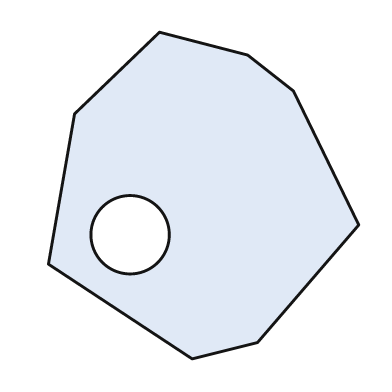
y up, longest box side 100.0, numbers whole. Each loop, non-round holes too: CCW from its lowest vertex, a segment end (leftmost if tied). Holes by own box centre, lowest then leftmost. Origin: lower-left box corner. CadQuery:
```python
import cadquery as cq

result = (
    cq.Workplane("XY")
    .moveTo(44.0, 0.0)
    .lineTo(64.0, 5.0)
    .lineTo(95.0, 41.0)
    .lineTo(75.0, 82.0)
    .lineTo(61.0, 93.0)
    .lineTo(34.0, 100.0)
    .lineTo(8.0, 75.0)
    .lineTo(0.0, 29.0)
    .close()
    .moveTo(25.0, 38.0)
    .circle(12.0)
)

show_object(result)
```